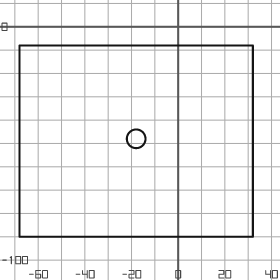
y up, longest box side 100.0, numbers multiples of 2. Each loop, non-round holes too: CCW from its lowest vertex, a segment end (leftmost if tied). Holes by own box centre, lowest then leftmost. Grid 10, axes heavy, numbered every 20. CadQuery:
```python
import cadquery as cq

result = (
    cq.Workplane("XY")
    .moveTo(-68.0, -90.0)
    .lineTo(32.0, -90.0)
    .lineTo(32.0, -8.0)
    .lineTo(-68.0, -8.0)
    .close()
    .moveTo(-18.0, -48.0)
    .circle(4.0)
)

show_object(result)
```